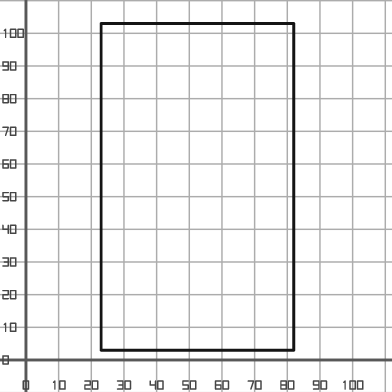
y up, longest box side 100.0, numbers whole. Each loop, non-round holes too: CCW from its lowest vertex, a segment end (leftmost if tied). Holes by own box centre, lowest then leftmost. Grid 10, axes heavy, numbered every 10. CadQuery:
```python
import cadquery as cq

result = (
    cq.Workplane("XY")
    .moveTo(23.0, 3.0)
    .lineTo(82.0, 3.0)
    .lineTo(82.0, 103.0)
    .lineTo(23.0, 103.0)
    .close()
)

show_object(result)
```